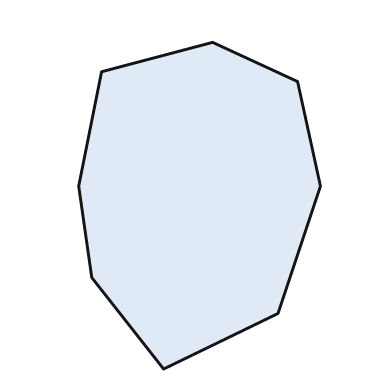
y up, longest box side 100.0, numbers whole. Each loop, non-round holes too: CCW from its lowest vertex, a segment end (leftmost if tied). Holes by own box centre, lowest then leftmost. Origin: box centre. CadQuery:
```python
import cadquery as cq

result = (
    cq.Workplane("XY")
    .moveTo(-11.0, -50.0)
    .lineTo(24.0, -33.0)
    .lineTo(37.0, 6.0)
    .lineTo(30.0, 38.0)
    .lineTo(4.0, 50.0)
    .lineTo(-30.0, 41.0)
    .lineTo(-37.0, 6.0)
    .lineTo(-33.0, -22.0)
    .close()
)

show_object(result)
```